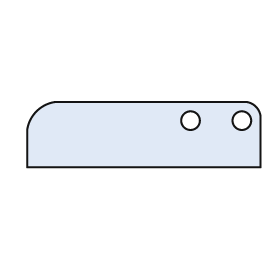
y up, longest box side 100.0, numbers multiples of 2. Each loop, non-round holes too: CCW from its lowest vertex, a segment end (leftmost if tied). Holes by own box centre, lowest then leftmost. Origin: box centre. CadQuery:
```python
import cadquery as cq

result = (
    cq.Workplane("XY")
    .moveTo(-50.0, -14.0)
    .lineTo(50.0, -14.0)
    .lineTo(50.0, 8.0)
    .threePointArc((48.0, 12.0), (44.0, 14.0))
    .lineTo(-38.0, 14.0)
    .threePointArc((-46.0, 10.0), (-50.0, 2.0))
    .close()
    .moveTo(20.0, 6.0)
    .circle(4.0)
    .moveTo(42.0, 6.0)
    .circle(4.0)
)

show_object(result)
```